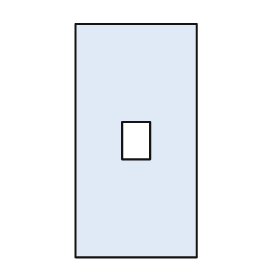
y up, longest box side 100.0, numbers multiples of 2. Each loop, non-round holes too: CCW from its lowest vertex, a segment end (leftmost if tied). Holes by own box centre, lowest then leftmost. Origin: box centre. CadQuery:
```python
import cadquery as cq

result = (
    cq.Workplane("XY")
    .moveTo(-26.0, -50.0)
    .lineTo(26.0, -50.0)
    .lineTo(26.0, 50.0)
    .lineTo(-26.0, 50.0)
    .close()
    .moveTo(-6.0, -8.0)
    .lineTo(6.0, -8.0)
    .lineTo(6.0, 8.0)
    .lineTo(-6.0, 8.0)
    .close()
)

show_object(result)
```